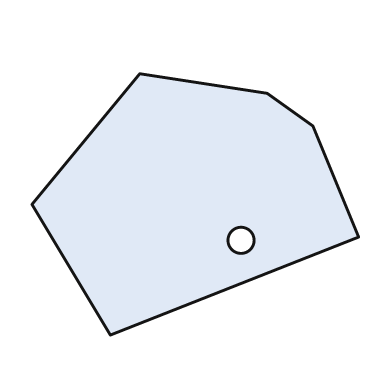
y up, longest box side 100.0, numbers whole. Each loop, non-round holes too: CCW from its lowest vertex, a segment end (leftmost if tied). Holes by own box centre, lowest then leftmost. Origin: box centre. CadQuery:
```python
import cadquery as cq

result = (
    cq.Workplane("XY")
    .moveTo(-26.0, -40.0)
    .lineTo(50.0, -10.0)
    .lineTo(36.0, 24.0)
    .lineTo(22.0, 34.0)
    .lineTo(-17.0, 40.0)
    .lineTo(-50.0, 0.0)
    .close()
    .moveTo(14.0, -11.0)
    .circle(4.0)
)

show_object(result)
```